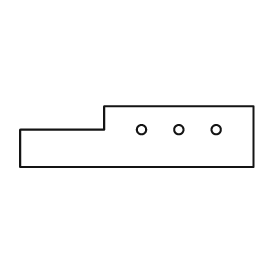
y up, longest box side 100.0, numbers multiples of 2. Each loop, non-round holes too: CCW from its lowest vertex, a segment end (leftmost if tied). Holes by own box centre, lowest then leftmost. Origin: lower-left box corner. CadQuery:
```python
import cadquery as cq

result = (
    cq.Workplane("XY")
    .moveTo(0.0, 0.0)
    .lineTo(100.0, 0.0)
    .lineTo(100.0, 26.0)
    .lineTo(36.0, 26.0)
    .lineTo(36.0, 16.0)
    .lineTo(0.0, 16.0)
    .close()
    .moveTo(52.0, 16.0)
    .circle(2.0)
    .moveTo(68.0, 16.0)
    .circle(2.0)
    .moveTo(84.0, 16.0)
    .circle(2.0)
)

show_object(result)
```